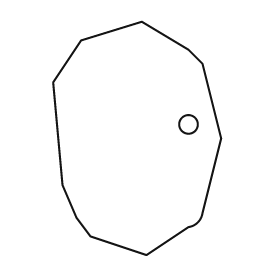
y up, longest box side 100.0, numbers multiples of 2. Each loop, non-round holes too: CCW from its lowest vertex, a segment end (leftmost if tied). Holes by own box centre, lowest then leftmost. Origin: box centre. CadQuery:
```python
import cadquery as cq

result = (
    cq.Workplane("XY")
    .moveTo(4.0, -50.0)
    .lineTo(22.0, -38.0)
    .threePointArc((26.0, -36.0), (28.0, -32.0))
    .lineTo(36.0, 0.0)
    .lineTo(28.0, 32.0)
    .lineTo(22.0, 38.0)
    .lineTo(2.0, 50.0)
    .lineTo(-24.0, 42.0)
    .lineTo(-36.0, 24.0)
    .lineTo(-32.0, -20.0)
    .lineTo(-26.0, -34.0)
    .lineTo(-20.0, -42.0)
    .close()
    .moveTo(22.0, 6.0)
    .circle(4.0)
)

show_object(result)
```